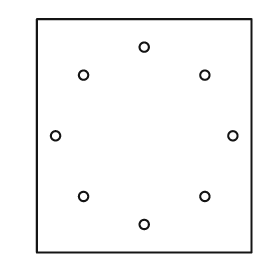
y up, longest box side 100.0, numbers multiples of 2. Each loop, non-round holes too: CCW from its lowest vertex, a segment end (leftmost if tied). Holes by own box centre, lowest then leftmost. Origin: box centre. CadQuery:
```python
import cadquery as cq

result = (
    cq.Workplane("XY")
    .moveTo(-46.0, -50.0)
    .lineTo(46.0, -50.0)
    .lineTo(46.0, 50.0)
    .lineTo(-46.0, 50.0)
    .close()
    .moveTo(0.0, -38.0)
    .circle(2.0)
    .moveTo(-26.0, -26.0)
    .circle(2.0)
    .moveTo(26.0, -26.0)
    .circle(2.0)
    .moveTo(-38.0, 0.0)
    .circle(2.0)
    .moveTo(38.0, 0.0)
    .circle(2.0)
    .moveTo(-26.0, 26.0)
    .circle(2.0)
    .moveTo(26.0, 26.0)
    .circle(2.0)
    .moveTo(0.0, 38.0)
    .circle(2.0)
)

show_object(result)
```